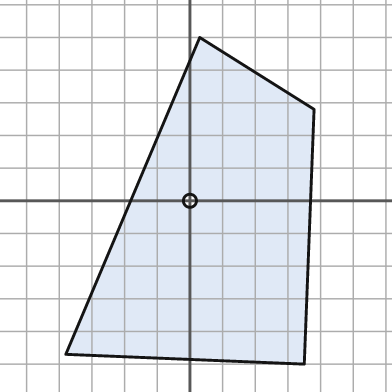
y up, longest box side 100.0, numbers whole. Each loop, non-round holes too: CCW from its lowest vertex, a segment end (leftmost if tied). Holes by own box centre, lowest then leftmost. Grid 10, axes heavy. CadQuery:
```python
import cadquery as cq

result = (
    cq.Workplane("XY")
    .moveTo(35.0, -50.0)
    .lineTo(38.0, 28.0)
    .lineTo(3.0, 50.0)
    .lineTo(-38.0, -47.0)
    .close()
    .moveTo(0.0, 0.0)
    .circle(2.0)
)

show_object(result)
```